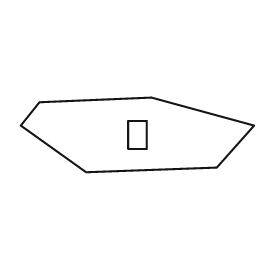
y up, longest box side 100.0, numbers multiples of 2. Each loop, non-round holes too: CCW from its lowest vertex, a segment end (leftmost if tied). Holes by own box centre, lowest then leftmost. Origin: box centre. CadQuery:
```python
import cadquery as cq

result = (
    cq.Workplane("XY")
    .moveTo(-22.0, -16.0)
    .lineTo(34.0, -14.0)
    .lineTo(50.0, 4.0)
    .lineTo(6.0, 16.0)
    .lineTo(-42.0, 14.0)
    .lineTo(-50.0, 4.0)
    .close()
    .moveTo(-4.0, -6.0)
    .lineTo(4.0, -6.0)
    .lineTo(4.0, 6.0)
    .lineTo(-4.0, 6.0)
    .close()
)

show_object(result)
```